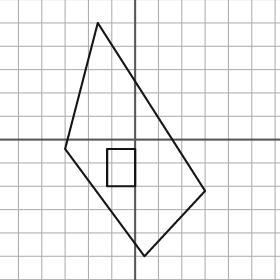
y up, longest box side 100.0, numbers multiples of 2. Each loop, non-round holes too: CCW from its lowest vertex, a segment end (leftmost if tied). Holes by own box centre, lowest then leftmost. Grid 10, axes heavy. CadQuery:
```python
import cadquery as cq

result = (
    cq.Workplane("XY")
    .moveTo(4.0, -50.0)
    .lineTo(30.0, -22.0)
    .lineTo(-16.0, 50.0)
    .lineTo(-30.0, -4.0)
    .close()
    .moveTo(-12.0, -20.0)
    .lineTo(0.0, -20.0)
    .lineTo(0.0, -4.0)
    .lineTo(-12.0, -4.0)
    .close()
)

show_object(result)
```